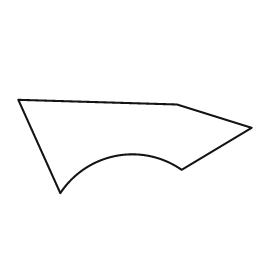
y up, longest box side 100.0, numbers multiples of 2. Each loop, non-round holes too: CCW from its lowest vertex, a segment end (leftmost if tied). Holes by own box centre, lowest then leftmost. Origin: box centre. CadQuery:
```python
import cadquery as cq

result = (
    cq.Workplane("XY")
    .moveTo(-32.0, -20.0)
    .threePointArc((-8.0, -4.0), (20.0, -10.0))
    .lineTo(50.0, 8.0)
    .lineTo(18.0, 18.0)
    .lineTo(-50.0, 20.0)
    .close()
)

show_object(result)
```